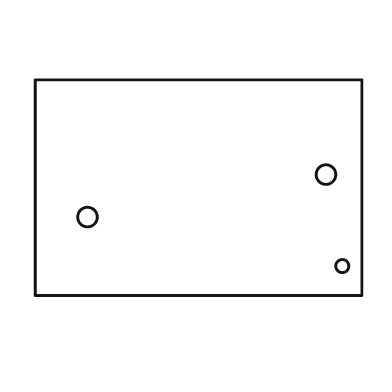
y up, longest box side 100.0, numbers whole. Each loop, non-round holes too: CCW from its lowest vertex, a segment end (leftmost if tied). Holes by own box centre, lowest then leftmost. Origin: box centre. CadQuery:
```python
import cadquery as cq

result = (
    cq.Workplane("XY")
    .moveTo(-50.0, -33.0)
    .lineTo(50.0, -33.0)
    .lineTo(50.0, 33.0)
    .lineTo(-50.0, 33.0)
    .close()
    .moveTo(44.0, -24.0)
    .circle(2.0)
    .moveTo(-34.0, -9.0)
    .circle(3.0)
    .moveTo(39.0, 4.0)
    .circle(3.0)
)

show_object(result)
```